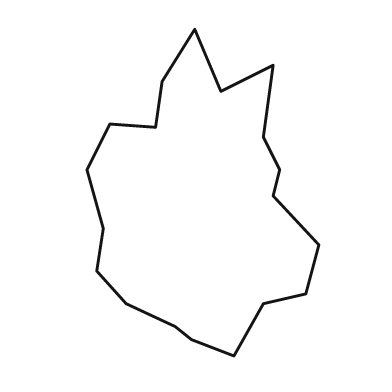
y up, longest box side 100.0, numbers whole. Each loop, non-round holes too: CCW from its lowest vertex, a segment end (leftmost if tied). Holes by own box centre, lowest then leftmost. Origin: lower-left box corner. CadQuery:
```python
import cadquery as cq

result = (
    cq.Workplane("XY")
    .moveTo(45.0, 0.0)
    .lineTo(54.0, 16.0)
    .lineTo(67.0, 19.0)
    .lineTo(71.0, 34.0)
    .lineTo(57.0, 49.0)
    .lineTo(59.0, 57.0)
    .lineTo(54.0, 67.0)
    .lineTo(57.0, 89.0)
    .lineTo(41.0, 81.0)
    .lineTo(33.0, 100.0)
    .lineTo(23.0, 84.0)
    .lineTo(21.0, 70.0)
    .lineTo(7.0, 71.0)
    .lineTo(0.0, 57.0)
    .lineTo(5.0, 39.0)
    .lineTo(3.0, 26.0)
    .lineTo(12.0, 16.0)
    .lineTo(27.0, 9.0)
    .lineTo(32.0, 5.0)
    .close()
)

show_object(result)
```